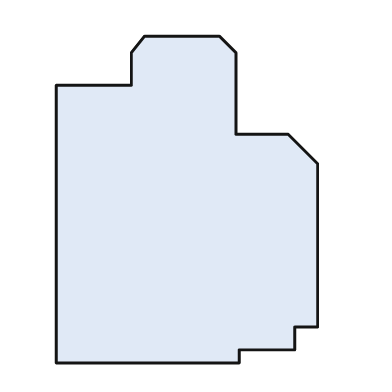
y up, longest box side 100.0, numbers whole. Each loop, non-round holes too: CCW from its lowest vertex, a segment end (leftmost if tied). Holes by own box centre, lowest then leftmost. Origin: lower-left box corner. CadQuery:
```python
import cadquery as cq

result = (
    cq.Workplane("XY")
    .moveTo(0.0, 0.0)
    .lineTo(56.0, 0.0)
    .lineTo(56.0, 4.0)
    .lineTo(73.0, 4.0)
    .lineTo(73.0, 11.0)
    .lineTo(80.0, 11.0)
    .lineTo(80.0, 61.0)
    .lineTo(71.0, 70.0)
    .lineTo(55.0, 70.0)
    .lineTo(55.0, 95.0)
    .lineTo(50.0, 100.0)
    .lineTo(27.0, 100.0)
    .lineTo(23.0, 95.0)
    .lineTo(23.0, 85.0)
    .lineTo(0.0, 85.0)
    .close()
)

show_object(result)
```